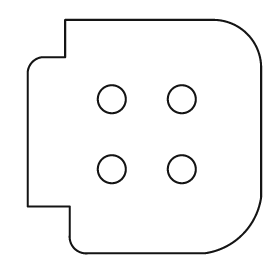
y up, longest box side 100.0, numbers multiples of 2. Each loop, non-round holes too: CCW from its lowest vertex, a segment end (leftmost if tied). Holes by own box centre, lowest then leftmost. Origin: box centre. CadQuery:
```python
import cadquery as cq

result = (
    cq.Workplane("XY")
    .moveTo(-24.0, -50.0)
    .lineTo(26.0, -50.0)
    .threePointArc((42.0, -42.0), (50.0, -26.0))
    .lineTo(50.0, 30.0)
    .threePointArc((44.0, 44.0), (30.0, 50.0))
    .lineTo(-34.0, 50.0)
    .lineTo(-34.0, 34.0)
    .lineTo(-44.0, 34.0)
    .threePointArc((-48.0, 32.0), (-50.0, 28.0))
    .lineTo(-50.0, -30.0)
    .lineTo(-32.0, -30.0)
    .lineTo(-32.0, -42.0)
    .threePointArc((-30.0, -48.0), (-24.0, -50.0))
    .close()
    .moveTo(-14.0, -14.0)
    .circle(6.0)
    .moveTo(16.0, -14.0)
    .circle(6.0)
    .moveTo(-14.0, 16.0)
    .circle(6.0)
    .moveTo(16.0, 16.0)
    .circle(6.0)
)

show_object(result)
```